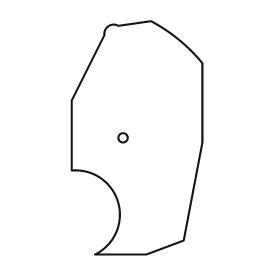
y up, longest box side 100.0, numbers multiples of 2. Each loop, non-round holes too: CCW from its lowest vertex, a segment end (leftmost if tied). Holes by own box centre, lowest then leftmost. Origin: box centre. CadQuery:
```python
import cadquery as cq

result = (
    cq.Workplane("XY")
    .moveTo(-18.0, -50.0)
    .lineTo(4.0, -50.0)
    .lineTo(20.0, -44.0)
    .lineTo(28.0, -2.0)
    .lineTo(28.0, 32.0)
    .threePointArc((18.0, 42.0), (6.0, 50.0))
    .lineTo(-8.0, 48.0)
    .threePointArc((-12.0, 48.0), (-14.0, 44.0))
    .lineTo(-28.0, 16.0)
    .lineTo(-28.0, -14.0)
    .threePointArc((-8.0, -28.0), (-18.0, -50.0))
    .close()
    .moveTo(-6.0, 0.0)
    .circle(2.0)
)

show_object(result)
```